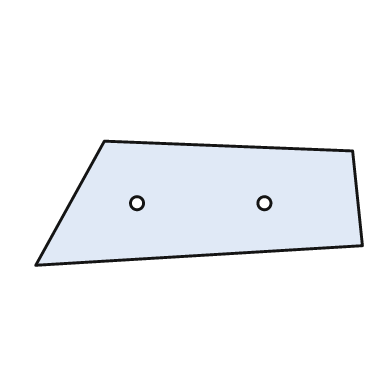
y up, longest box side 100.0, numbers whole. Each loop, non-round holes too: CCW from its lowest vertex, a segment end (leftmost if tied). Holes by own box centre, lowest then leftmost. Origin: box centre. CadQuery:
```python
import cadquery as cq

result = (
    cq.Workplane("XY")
    .moveTo(-50.0, -19.0)
    .lineTo(50.0, -13.0)
    .lineTo(47.0, 16.0)
    .lineTo(-29.0, 19.0)
    .close()
    .moveTo(-19.0, 0.0)
    .circle(2.0)
    .moveTo(20.0, 0.0)
    .circle(2.0)
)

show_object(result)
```